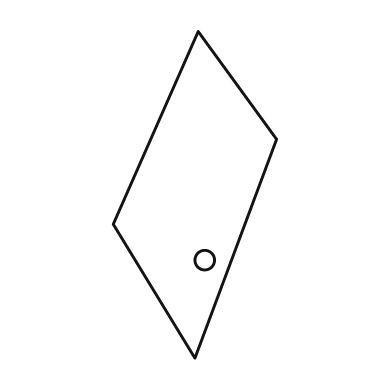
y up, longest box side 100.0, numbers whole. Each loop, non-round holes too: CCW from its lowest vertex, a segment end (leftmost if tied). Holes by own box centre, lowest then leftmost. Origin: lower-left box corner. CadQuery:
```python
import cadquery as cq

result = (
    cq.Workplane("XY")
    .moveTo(25.0, 0.0)
    .lineTo(50.0, 67.0)
    .lineTo(26.0, 100.0)
    .lineTo(0.0, 41.0)
    .close()
    .moveTo(28.0, 30.0)
    .circle(3.0)
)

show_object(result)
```